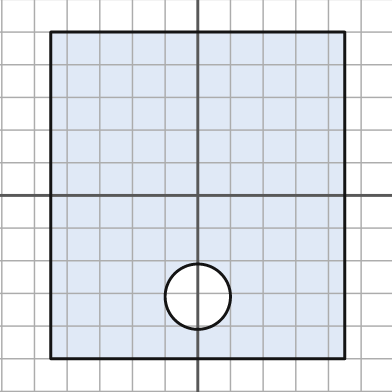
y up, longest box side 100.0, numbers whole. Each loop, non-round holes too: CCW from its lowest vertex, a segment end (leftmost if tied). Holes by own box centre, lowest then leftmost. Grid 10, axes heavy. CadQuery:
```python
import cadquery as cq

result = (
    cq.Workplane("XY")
    .moveTo(-45.0, -50.0)
    .lineTo(45.0, -50.0)
    .lineTo(45.0, 50.0)
    .lineTo(-45.0, 50.0)
    .close()
    .moveTo(0.0, -31.0)
    .circle(10.0)
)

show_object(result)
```